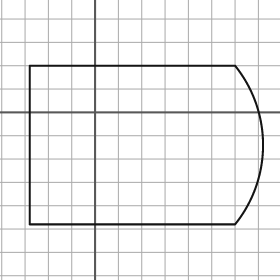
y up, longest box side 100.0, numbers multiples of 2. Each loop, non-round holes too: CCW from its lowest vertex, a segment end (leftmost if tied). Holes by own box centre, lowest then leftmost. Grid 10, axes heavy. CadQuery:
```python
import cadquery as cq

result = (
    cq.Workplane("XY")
    .moveTo(-28.0, -48.0)
    .lineTo(60.0, -48.0)
    .threePointArc((72.0, -14.0), (60.0, 20.0))
    .lineTo(-28.0, 20.0)
    .close()
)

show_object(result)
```